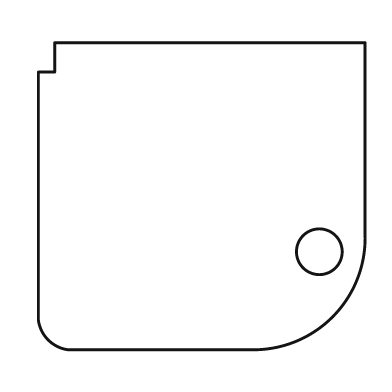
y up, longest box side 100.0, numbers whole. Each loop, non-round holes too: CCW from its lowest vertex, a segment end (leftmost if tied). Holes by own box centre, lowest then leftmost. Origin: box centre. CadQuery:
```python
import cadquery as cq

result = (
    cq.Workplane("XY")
    .moveTo(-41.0, -47.0)
    .lineTo(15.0, -47.0)
    .threePointArc((40.0, -37.0), (50.0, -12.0))
    .lineTo(50.0, 47.0)
    .lineTo(-45.0, 47.0)
    .lineTo(-45.0, 38.0)
    .lineTo(-50.0, 38.0)
    .lineTo(-50.0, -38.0)
    .threePointArc((-47.0, -44.0), (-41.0, -47.0))
    .close()
    .moveTo(36.0, -17.0)
    .circle(7.0)
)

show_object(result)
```